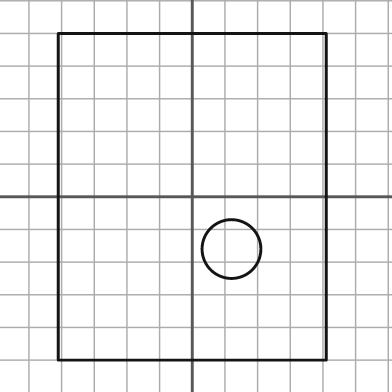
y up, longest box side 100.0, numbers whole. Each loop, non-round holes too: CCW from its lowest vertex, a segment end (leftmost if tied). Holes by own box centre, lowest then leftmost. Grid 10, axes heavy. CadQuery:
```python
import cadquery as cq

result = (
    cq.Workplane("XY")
    .moveTo(-41.0, -50.0)
    .lineTo(41.0, -50.0)
    .lineTo(41.0, 50.0)
    .lineTo(-41.0, 50.0)
    .close()
    .moveTo(12.0, -16.0)
    .circle(9.0)
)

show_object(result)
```